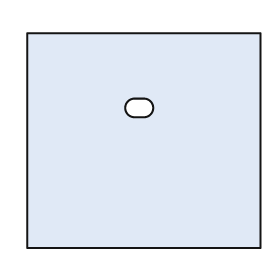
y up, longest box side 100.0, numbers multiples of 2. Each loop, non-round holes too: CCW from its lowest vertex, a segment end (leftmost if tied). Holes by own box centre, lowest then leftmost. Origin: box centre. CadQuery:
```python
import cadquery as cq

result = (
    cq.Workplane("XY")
    .moveTo(-50.0, -46.0)
    .lineTo(50.0, -46.0)
    .lineTo(50.0, 46.0)
    .lineTo(-50.0, 46.0)
    .close()
    .moveTo(-4.0, 10.0)
    .lineTo(0.0, 10.0)
    .threePointArc((4.0, 14.0), (0.0, 18.0))
    .lineTo(-4.0, 18.0)
    .threePointArc((-8.0, 14.0), (-4.0, 10.0))
    .close()
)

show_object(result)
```